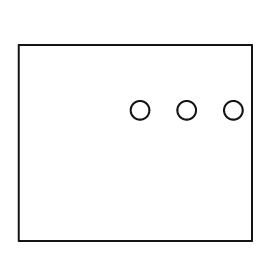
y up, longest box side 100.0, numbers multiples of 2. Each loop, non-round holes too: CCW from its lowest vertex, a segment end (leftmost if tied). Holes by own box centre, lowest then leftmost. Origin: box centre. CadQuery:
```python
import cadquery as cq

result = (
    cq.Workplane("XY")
    .moveTo(-50.0, -42.0)
    .lineTo(50.0, -42.0)
    .lineTo(50.0, 42.0)
    .lineTo(-50.0, 42.0)
    .close()
    .moveTo(2.0, 14.0)
    .circle(4.0)
    .moveTo(22.0, 14.0)
    .circle(4.0)
    .moveTo(42.0, 14.0)
    .circle(4.0)
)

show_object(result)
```